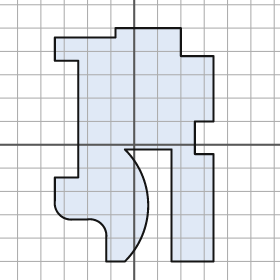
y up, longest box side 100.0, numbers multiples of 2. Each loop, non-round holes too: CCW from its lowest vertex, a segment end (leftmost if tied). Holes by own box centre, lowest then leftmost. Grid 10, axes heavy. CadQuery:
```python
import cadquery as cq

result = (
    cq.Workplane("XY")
    .moveTo(-12.0, -50.0)
    .lineTo(-4.0, -50.0)
    .threePointArc((6.0, -26.0), (-4.0, -2.0))
    .lineTo(16.0, -2.0)
    .lineTo(16.0, -50.0)
    .lineTo(34.0, -50.0)
    .lineTo(34.0, -4.0)
    .lineTo(26.0, -4.0)
    .lineTo(26.0, 10.0)
    .lineTo(34.0, 10.0)
    .lineTo(34.0, 38.0)
    .lineTo(20.0, 38.0)
    .lineTo(20.0, 50.0)
    .lineTo(-8.0, 50.0)
    .lineTo(-8.0, 46.0)
    .lineTo(-34.0, 46.0)
    .lineTo(-34.0, 36.0)
    .lineTo(-24.0, 36.0)
    .lineTo(-24.0, -14.0)
    .lineTo(-34.0, -14.0)
    .lineTo(-34.0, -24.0)
    .threePointArc((-32.0, -30.0), (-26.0, -32.0))
    .lineTo(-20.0, -32.0)
    .threePointArc((-14.0, -34.0), (-12.0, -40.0))
    .close()
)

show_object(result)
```